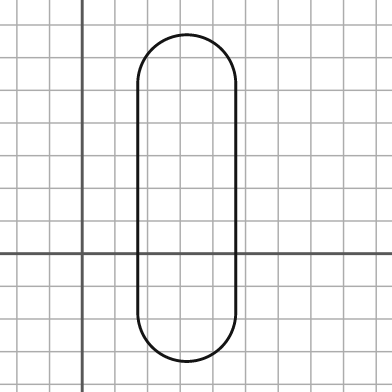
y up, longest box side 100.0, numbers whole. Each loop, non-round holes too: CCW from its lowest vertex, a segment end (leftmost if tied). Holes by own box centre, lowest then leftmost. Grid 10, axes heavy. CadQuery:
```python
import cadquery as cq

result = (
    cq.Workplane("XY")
    .moveTo(17.0, -18.0)
    .threePointArc((32.0, -33.0), (47.0, -18.0))
    .lineTo(47.0, 52.0)
    .threePointArc((32.0, 67.0), (17.0, 52.0))
    .close()
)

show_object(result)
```